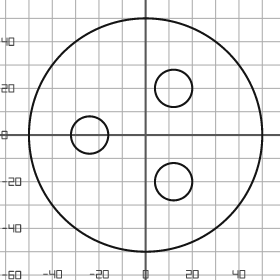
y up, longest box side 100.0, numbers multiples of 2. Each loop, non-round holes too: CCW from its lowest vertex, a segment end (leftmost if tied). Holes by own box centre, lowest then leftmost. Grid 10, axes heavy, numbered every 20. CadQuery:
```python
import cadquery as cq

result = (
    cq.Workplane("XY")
    .moveTo(0.0, 0.0)
    .circle(50.0)
    .moveTo(12.0, -20.0)
    .circle(8.0)
    .moveTo(-24.0, 0.0)
    .circle(8.0)
    .moveTo(12.0, 20.0)
    .circle(8.0)
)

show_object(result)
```